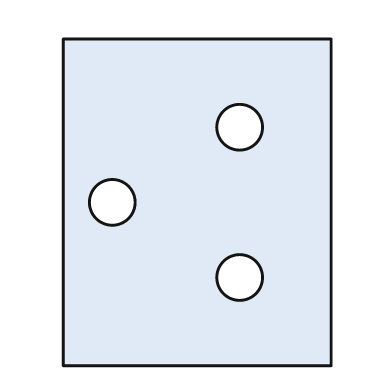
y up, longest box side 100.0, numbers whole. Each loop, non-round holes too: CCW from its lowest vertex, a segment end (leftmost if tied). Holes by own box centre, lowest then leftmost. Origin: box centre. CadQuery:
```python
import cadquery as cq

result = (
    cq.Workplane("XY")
    .moveTo(-41.0, -50.0)
    .lineTo(41.0, -50.0)
    .lineTo(41.0, 50.0)
    .lineTo(-41.0, 50.0)
    .close()
    .moveTo(13.0, -23.0)
    .circle(7.0)
    .moveTo(-26.0, 0.0)
    .circle(7.0)
    .moveTo(13.0, 23.0)
    .circle(7.0)
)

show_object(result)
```